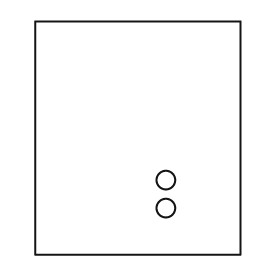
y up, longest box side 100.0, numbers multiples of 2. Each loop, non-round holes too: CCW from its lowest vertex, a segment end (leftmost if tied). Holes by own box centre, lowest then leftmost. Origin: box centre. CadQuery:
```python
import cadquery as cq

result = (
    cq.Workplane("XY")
    .moveTo(-44.0, -50.0)
    .lineTo(44.0, -50.0)
    .lineTo(44.0, 50.0)
    .lineTo(-44.0, 50.0)
    .close()
    .moveTo(12.0, -30.0)
    .circle(4.0)
    .moveTo(12.0, -18.0)
    .circle(4.0)
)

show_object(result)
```